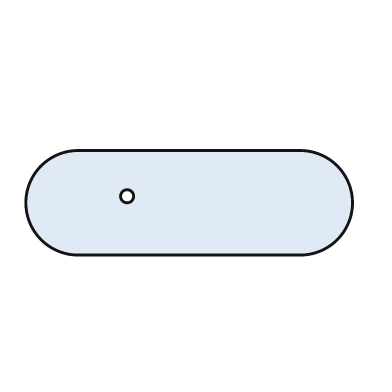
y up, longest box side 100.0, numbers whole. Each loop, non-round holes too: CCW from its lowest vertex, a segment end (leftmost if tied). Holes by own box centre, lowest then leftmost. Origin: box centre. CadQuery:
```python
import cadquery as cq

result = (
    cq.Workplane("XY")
    .moveTo(-34.0, -16.0)
    .lineTo(34.0, -16.0)
    .threePointArc((50.0, 0.0), (34.0, 16.0))
    .lineTo(-34.0, 16.0)
    .threePointArc((-50.0, 0.0), (-34.0, -16.0))
    .close()
    .moveTo(-19.0, 2.0)
    .circle(2.0)
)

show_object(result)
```